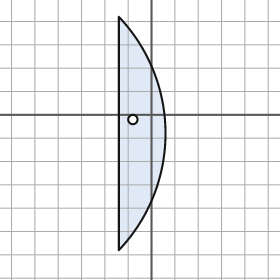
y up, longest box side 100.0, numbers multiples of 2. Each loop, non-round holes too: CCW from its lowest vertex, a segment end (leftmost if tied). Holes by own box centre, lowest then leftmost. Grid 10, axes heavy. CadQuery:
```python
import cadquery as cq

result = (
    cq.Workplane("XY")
    .moveTo(-14.0, -58.0)
    .threePointArc((6.0, -8.0), (-14.0, 42.0))
    .close()
    .moveTo(-8.0, -2.0)
    .circle(2.0)
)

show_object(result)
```